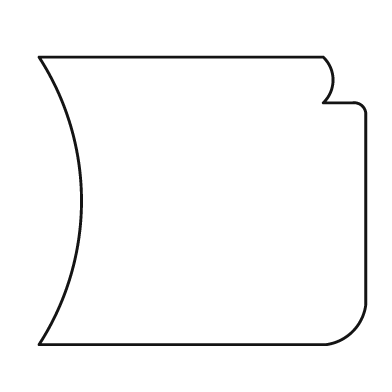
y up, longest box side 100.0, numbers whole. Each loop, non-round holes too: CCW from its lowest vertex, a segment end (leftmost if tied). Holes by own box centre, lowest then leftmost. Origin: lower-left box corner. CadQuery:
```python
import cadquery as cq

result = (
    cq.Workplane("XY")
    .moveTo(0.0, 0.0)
    .lineTo(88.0, 0.0)
    .threePointArc((96.0, 4.0), (100.0, 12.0))
    .lineTo(100.0, 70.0)
    .threePointArc((99.0, 73.0), (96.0, 74.0))
    .lineTo(87.0, 74.0)
    .threePointArc((90.0, 81.0), (87.0, 88.0))
    .lineTo(0.0, 88.0)
    .threePointArc((13.0, 44.0), (0.0, 0.0))
    .close()
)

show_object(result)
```